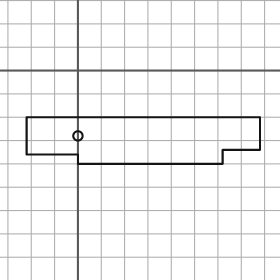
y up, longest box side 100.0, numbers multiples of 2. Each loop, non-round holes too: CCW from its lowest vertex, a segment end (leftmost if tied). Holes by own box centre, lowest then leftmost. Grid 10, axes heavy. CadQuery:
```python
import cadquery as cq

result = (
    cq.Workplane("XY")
    .moveTo(0.0, -40.0)
    .lineTo(62.0, -40.0)
    .lineTo(62.0, -34.0)
    .lineTo(78.0, -34.0)
    .lineTo(78.0, -20.0)
    .lineTo(-22.0, -20.0)
    .lineTo(-22.0, -36.0)
    .lineTo(0.0, -36.0)
    .close()
    .moveTo(0.0, -28.0)
    .circle(2.0)
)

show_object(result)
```